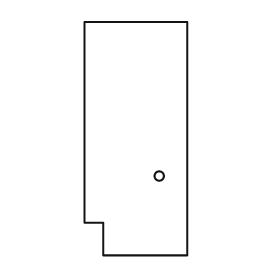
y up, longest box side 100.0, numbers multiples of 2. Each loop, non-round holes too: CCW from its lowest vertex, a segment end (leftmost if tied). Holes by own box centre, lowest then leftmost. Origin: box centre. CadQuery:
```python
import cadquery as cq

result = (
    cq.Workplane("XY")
    .moveTo(-14.0, -50.0)
    .lineTo(22.0, -50.0)
    .lineTo(22.0, 50.0)
    .lineTo(-22.0, 50.0)
    .lineTo(-22.0, -36.0)
    .lineTo(-14.0, -36.0)
    .close()
    .moveTo(10.0, -16.0)
    .circle(2.0)
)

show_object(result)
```